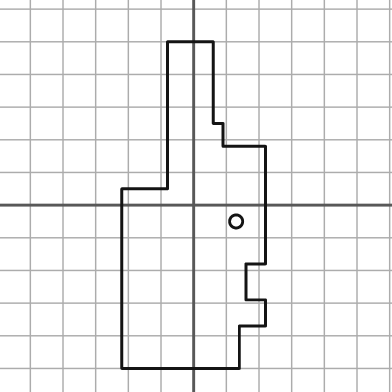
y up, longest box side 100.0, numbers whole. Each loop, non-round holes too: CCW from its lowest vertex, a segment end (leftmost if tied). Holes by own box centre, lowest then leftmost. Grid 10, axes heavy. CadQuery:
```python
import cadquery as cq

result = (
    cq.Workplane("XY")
    .moveTo(-22.0, -50.0)
    .lineTo(14.0, -50.0)
    .lineTo(14.0, -37.0)
    .lineTo(22.0, -37.0)
    .lineTo(22.0, -29.0)
    .lineTo(16.0, -29.0)
    .lineTo(16.0, -18.0)
    .lineTo(22.0, -18.0)
    .lineTo(22.0, 18.0)
    .lineTo(9.0, 18.0)
    .lineTo(9.0, 25.0)
    .lineTo(6.0, 25.0)
    .lineTo(6.0, 50.0)
    .lineTo(-8.0, 50.0)
    .lineTo(-8.0, 5.0)
    .lineTo(-22.0, 5.0)
    .close()
    .moveTo(13.0, -5.0)
    .circle(2.0)
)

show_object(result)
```